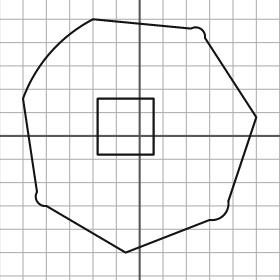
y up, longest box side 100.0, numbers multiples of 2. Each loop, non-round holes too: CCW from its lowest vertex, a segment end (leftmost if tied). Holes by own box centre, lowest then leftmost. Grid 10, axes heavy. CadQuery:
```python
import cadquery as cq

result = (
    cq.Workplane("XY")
    .moveTo(-6.0, -50.0)
    .lineTo(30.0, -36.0)
    .threePointArc((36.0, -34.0), (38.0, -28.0))
    .lineTo(50.0, 8.0)
    .lineTo(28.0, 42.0)
    .threePointArc((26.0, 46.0), (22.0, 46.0))
    .lineTo(-20.0, 50.0)
    .threePointArc((-38.0, 36.0), (-50.0, 16.0))
    .lineTo(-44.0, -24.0)
    .threePointArc((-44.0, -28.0), (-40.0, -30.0))
    .close()
    .moveTo(-18.0, -8.0)
    .lineTo(6.0, -8.0)
    .lineTo(6.0, 16.0)
    .lineTo(-18.0, 16.0)
    .close()
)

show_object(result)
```